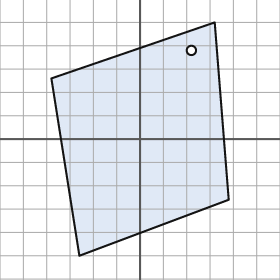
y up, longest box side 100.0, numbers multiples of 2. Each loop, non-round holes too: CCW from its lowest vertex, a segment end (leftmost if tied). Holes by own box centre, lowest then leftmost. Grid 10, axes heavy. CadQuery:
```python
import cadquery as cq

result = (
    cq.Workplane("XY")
    .moveTo(-26.0, -50.0)
    .lineTo(38.0, -26.0)
    .lineTo(32.0, 50.0)
    .lineTo(-38.0, 26.0)
    .close()
    .moveTo(22.0, 38.0)
    .circle(2.0)
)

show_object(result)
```